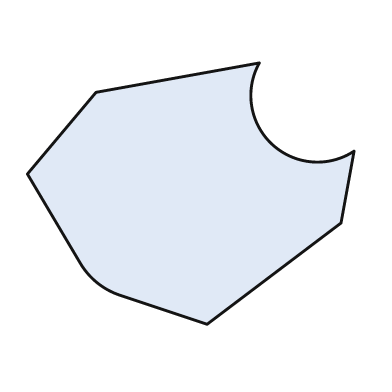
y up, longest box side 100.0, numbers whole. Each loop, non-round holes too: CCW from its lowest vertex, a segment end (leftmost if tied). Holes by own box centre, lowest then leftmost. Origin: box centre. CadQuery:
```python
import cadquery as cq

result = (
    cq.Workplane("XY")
    .moveTo(5.0, -40.0)
    .lineTo(46.0, -9.0)
    .lineTo(50.0, 13.0)
    .threePointArc((25.0, 15.0), (21.0, 40.0))
    .lineTo(-29.0, 31.0)
    .lineTo(-50.0, 6.0)
    .lineTo(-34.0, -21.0)
    .threePointArc((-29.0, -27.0), (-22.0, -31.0))
    .close()
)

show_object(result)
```